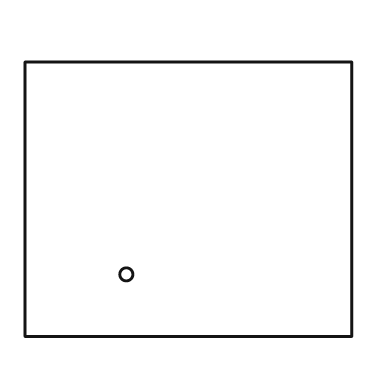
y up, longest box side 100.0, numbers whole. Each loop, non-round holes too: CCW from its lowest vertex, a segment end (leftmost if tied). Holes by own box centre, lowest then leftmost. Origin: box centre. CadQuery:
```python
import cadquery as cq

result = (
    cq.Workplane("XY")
    .moveTo(-50.0, -42.0)
    .lineTo(50.0, -42.0)
    .lineTo(50.0, 42.0)
    .lineTo(-50.0, 42.0)
    .close()
    .moveTo(-19.0, -23.0)
    .circle(2.0)
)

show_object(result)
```